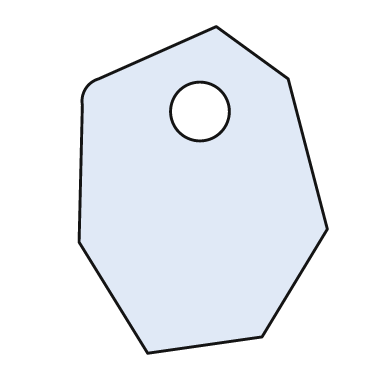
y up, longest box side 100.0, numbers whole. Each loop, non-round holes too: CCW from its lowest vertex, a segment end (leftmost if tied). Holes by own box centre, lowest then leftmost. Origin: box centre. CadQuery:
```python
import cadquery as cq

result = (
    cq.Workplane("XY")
    .moveTo(-17.0, -50.0)
    .lineTo(18.0, -45.0)
    .lineTo(38.0, -12.0)
    .lineTo(26.0, 34.0)
    .lineTo(4.0, 50.0)
    .lineTo(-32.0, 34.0)
    .threePointArc((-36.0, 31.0), (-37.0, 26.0))
    .lineTo(-38.0, -16.0)
    .close()
    .moveTo(-1.0, 24.0)
    .circle(9.0)
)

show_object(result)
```